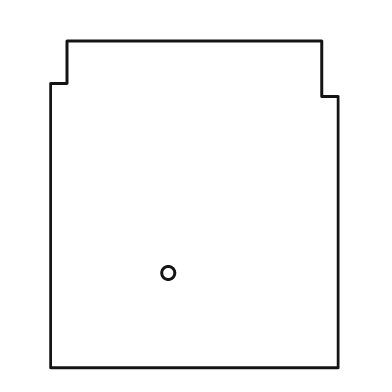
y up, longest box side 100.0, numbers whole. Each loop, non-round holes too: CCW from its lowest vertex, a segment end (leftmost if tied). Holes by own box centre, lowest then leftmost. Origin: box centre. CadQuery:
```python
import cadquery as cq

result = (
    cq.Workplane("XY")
    .moveTo(-44.0, -50.0)
    .lineTo(44.0, -50.0)
    .lineTo(44.0, 33.0)
    .lineTo(39.0, 33.0)
    .lineTo(39.0, 50.0)
    .lineTo(-39.0, 50.0)
    .lineTo(-39.0, 37.0)
    .lineTo(-44.0, 37.0)
    .close()
    .moveTo(-8.0, -21.0)
    .circle(2.0)
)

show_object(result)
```